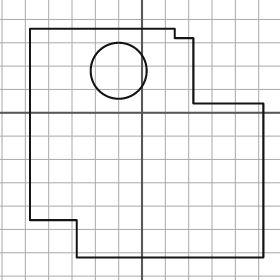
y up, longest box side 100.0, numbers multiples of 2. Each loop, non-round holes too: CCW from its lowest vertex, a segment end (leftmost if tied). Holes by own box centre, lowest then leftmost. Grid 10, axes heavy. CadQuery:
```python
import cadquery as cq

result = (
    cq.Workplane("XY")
    .moveTo(-28.0, -62.0)
    .lineTo(52.0, -62.0)
    .lineTo(52.0, 4.0)
    .lineTo(22.0, 4.0)
    .lineTo(22.0, 32.0)
    .lineTo(14.0, 32.0)
    .lineTo(14.0, 36.0)
    .lineTo(-48.0, 36.0)
    .lineTo(-48.0, -46.0)
    .lineTo(-28.0, -46.0)
    .close()
    .moveTo(-10.0, 18.0)
    .circle(12.0)
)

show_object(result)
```